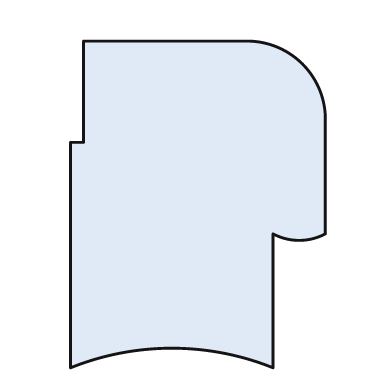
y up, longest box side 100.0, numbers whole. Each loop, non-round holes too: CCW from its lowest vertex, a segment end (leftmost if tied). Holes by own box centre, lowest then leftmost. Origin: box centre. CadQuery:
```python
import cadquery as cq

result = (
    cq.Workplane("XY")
    .moveTo(-39.0, -50.0)
    .threePointArc((-8.0, -44.0), (23.0, -50.0))
    .lineTo(23.0, -9.0)
    .threePointArc((31.0, -11.0), (39.0, -9.0))
    .lineTo(39.0, 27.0)
    .threePointArc((32.0, 43.0), (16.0, 50.0))
    .lineTo(-35.0, 50.0)
    .lineTo(-35.0, 19.0)
    .lineTo(-39.0, 19.0)
    .close()
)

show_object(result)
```